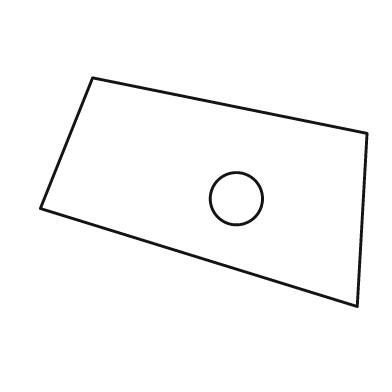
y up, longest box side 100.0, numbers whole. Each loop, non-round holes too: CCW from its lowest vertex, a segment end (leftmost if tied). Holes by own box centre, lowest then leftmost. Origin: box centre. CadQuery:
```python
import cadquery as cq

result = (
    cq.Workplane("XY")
    .moveTo(47.0, -35.0)
    .lineTo(50.0, 18.0)
    .lineTo(-34.0, 35.0)
    .lineTo(-50.0, -5.0)
    .close()
    .moveTo(10.0, -2.0)
    .circle(8.0)
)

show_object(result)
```